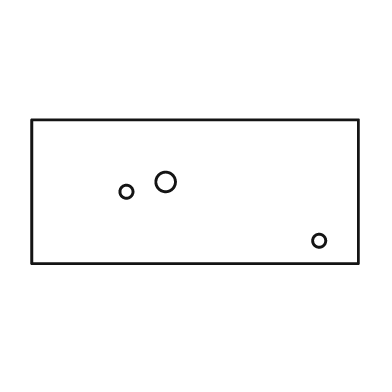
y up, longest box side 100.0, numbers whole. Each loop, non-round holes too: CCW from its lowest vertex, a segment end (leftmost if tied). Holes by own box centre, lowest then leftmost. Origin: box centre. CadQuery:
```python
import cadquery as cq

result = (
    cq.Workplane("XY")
    .moveTo(-50.0, -22.0)
    .lineTo(50.0, -22.0)
    .lineTo(50.0, 22.0)
    .lineTo(-50.0, 22.0)
    .close()
    .moveTo(38.0, -15.0)
    .circle(2.0)
    .moveTo(-21.0, 0.0)
    .circle(2.0)
    .moveTo(-9.0, 3.0)
    .circle(3.0)
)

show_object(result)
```